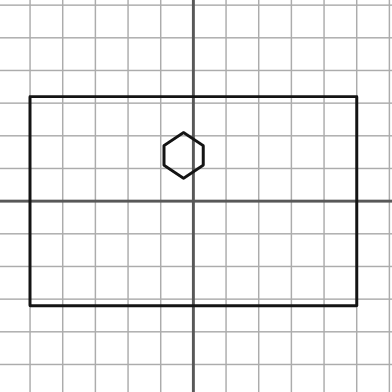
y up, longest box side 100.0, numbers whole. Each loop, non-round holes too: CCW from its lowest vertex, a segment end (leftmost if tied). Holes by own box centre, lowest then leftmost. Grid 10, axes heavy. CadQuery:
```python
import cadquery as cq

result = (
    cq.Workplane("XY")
    .moveTo(-50.0, -32.0)
    .lineTo(50.0, -32.0)
    .lineTo(50.0, 32.0)
    .lineTo(-50.0, 32.0)
    .close()
    .moveTo(-3.0, 7.0)
    .lineTo(3.0, 11.0)
    .lineTo(3.0, 17.0)
    .lineTo(-3.0, 21.0)
    .lineTo(-9.0, 17.0)
    .lineTo(-9.0, 11.0)
    .close()
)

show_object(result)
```